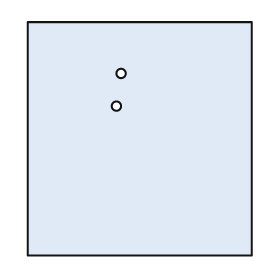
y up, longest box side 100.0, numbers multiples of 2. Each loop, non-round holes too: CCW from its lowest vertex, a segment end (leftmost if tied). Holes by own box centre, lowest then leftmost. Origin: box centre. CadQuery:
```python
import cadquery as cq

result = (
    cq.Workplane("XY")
    .moveTo(-48.0, -50.0)
    .lineTo(48.0, -50.0)
    .lineTo(48.0, 50.0)
    .lineTo(-48.0, 50.0)
    .close()
    .moveTo(-10.0, 14.0)
    .circle(2.0)
    .moveTo(-8.0, 28.0)
    .circle(2.0)
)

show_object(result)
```